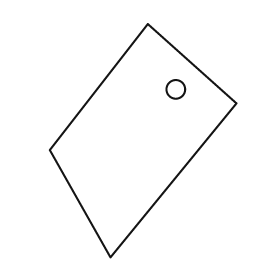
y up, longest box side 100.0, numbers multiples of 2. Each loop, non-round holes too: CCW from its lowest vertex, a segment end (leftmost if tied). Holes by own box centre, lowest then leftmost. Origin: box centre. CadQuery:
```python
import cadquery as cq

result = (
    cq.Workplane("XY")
    .moveTo(-14.0, -50.0)
    .lineTo(40.0, 16.0)
    .lineTo(2.0, 50.0)
    .lineTo(-40.0, -4.0)
    .close()
    .moveTo(14.0, 22.0)
    .circle(4.0)
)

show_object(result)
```